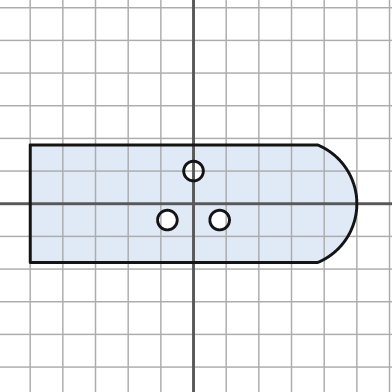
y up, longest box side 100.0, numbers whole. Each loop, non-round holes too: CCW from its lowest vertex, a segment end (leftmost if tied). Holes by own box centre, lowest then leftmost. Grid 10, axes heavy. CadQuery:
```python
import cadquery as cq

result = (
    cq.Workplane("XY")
    .moveTo(-50.0, -18.0)
    .lineTo(38.0, -18.0)
    .threePointArc((50.0, 0.0), (38.0, 18.0))
    .lineTo(-50.0, 18.0)
    .close()
    .moveTo(-8.0, -5.0)
    .circle(3.0)
    .moveTo(8.0, -5.0)
    .circle(3.0)
    .moveTo(0.0, 10.0)
    .circle(3.0)
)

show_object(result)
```